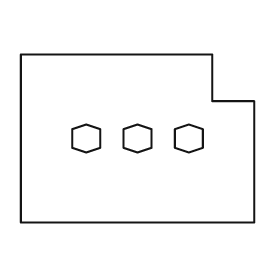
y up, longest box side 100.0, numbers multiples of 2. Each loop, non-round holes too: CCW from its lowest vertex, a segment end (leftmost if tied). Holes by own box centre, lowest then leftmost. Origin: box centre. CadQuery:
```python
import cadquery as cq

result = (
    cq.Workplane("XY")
    .moveTo(-50.0, -36.0)
    .lineTo(50.0, -36.0)
    .lineTo(50.0, 16.0)
    .lineTo(32.0, 16.0)
    .lineTo(32.0, 36.0)
    .lineTo(-50.0, 36.0)
    .close()
    .moveTo(-22.0, -6.0)
    .lineTo(-16.0, -4.0)
    .lineTo(-16.0, 4.0)
    .lineTo(-22.0, 6.0)
    .lineTo(-28.0, 4.0)
    .lineTo(-28.0, -4.0)
    .close()
    .moveTo(0.0, -6.0)
    .lineTo(6.0, -4.0)
    .lineTo(6.0, 4.0)
    .lineTo(0.0, 6.0)
    .lineTo(-6.0, 4.0)
    .lineTo(-6.0, -4.0)
    .close()
    .moveTo(22.0, -6.0)
    .lineTo(28.0, -4.0)
    .lineTo(28.0, 4.0)
    .lineTo(22.0, 6.0)
    .lineTo(16.0, 4.0)
    .lineTo(16.0, -4.0)
    .close()
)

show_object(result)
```